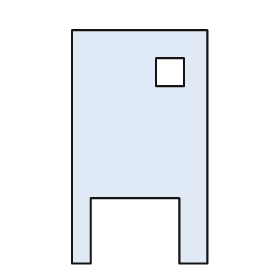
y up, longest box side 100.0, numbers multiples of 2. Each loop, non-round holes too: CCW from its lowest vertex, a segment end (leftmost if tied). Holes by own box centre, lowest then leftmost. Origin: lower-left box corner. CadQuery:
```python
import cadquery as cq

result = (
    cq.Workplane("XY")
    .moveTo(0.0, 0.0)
    .lineTo(8.0, 0.0)
    .lineTo(8.0, 28.0)
    .lineTo(46.0, 28.0)
    .lineTo(46.0, 0.0)
    .lineTo(58.0, 0.0)
    .lineTo(58.0, 100.0)
    .lineTo(0.0, 100.0)
    .close()
    .moveTo(36.0, 76.0)
    .lineTo(48.0, 76.0)
    .lineTo(48.0, 88.0)
    .lineTo(36.0, 88.0)
    .close()
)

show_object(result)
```